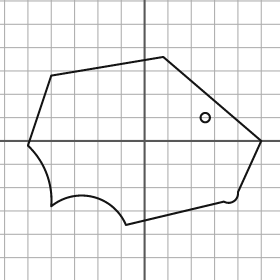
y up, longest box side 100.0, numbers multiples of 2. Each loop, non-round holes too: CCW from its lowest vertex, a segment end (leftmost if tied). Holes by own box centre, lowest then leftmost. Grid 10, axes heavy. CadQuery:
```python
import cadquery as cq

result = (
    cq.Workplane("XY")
    .moveTo(-8.0, -36.0)
    .lineTo(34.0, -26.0)
    .threePointArc((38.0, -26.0), (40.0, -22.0))
    .lineTo(50.0, 0.0)
    .lineTo(8.0, 36.0)
    .lineTo(-40.0, 28.0)
    .lineTo(-50.0, -2.0)
    .threePointArc((-42.0, -14.0), (-40.0, -28.0))
    .threePointArc((-22.0, -24.0), (-8.0, -36.0))
    .close()
    .moveTo(26.0, 10.0)
    .circle(2.0)
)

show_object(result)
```